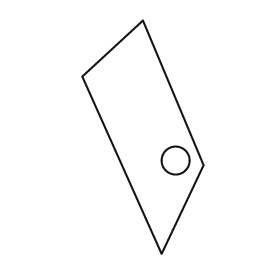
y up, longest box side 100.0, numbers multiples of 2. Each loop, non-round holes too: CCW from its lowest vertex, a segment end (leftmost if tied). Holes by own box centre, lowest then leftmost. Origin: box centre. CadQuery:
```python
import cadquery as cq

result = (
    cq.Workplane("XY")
    .moveTo(8.0, -50.0)
    .lineTo(26.0, -12.0)
    .lineTo(0.0, 50.0)
    .lineTo(-26.0, 26.0)
    .close()
    .moveTo(14.0, -10.0)
    .circle(6.0)
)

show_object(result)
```